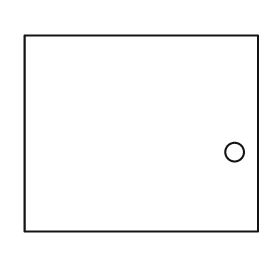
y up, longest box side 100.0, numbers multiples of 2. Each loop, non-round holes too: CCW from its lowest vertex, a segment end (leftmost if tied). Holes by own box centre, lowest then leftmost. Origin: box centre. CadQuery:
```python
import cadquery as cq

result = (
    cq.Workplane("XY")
    .moveTo(-50.0, -42.0)
    .lineTo(50.0, -42.0)
    .lineTo(50.0, 42.0)
    .lineTo(-50.0, 42.0)
    .close()
    .moveTo(40.0, -8.0)
    .circle(4.0)
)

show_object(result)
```